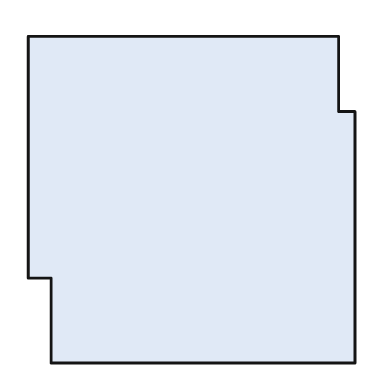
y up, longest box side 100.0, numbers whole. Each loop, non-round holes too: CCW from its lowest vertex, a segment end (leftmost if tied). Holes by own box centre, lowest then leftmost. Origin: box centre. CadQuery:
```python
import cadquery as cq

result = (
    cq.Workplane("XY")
    .moveTo(-43.0, -50.0)
    .lineTo(50.0, -50.0)
    .lineTo(50.0, 27.0)
    .lineTo(45.0, 27.0)
    .lineTo(45.0, 50.0)
    .lineTo(-50.0, 50.0)
    .lineTo(-50.0, -24.0)
    .lineTo(-43.0, -24.0)
    .close()
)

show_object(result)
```